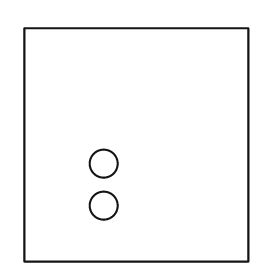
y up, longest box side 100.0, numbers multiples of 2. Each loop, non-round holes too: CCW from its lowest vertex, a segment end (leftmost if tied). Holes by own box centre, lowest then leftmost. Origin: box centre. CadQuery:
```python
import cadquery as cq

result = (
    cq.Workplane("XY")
    .moveTo(-48.0, -50.0)
    .lineTo(48.0, -50.0)
    .lineTo(48.0, 50.0)
    .lineTo(-48.0, 50.0)
    .close()
    .moveTo(-14.0, -26.0)
    .circle(6.0)
    .moveTo(-14.0, -8.0)
    .circle(6.0)
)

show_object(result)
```